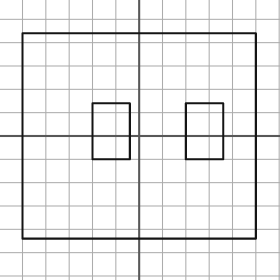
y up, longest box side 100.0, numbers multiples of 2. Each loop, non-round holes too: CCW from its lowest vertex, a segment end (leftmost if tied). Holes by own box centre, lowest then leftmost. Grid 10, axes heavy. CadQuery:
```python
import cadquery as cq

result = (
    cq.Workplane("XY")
    .moveTo(-50.0, -44.0)
    .lineTo(50.0, -44.0)
    .lineTo(50.0, 44.0)
    .lineTo(-50.0, 44.0)
    .close()
    .moveTo(-20.0, -10.0)
    .lineTo(-4.0, -10.0)
    .lineTo(-4.0, 14.0)
    .lineTo(-20.0, 14.0)
    .close()
    .moveTo(20.0, -10.0)
    .lineTo(36.0, -10.0)
    .lineTo(36.0, 14.0)
    .lineTo(20.0, 14.0)
    .close()
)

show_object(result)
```